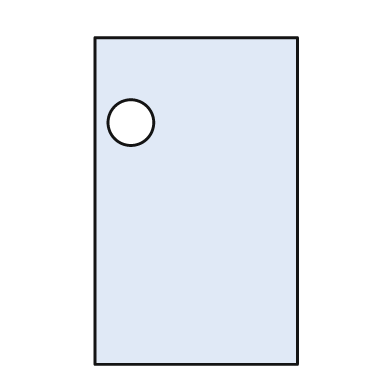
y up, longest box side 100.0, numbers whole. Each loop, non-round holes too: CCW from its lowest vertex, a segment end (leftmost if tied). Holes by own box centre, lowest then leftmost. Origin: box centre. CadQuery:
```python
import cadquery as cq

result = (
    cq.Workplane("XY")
    .moveTo(-31.0, -50.0)
    .lineTo(31.0, -50.0)
    .lineTo(31.0, 50.0)
    .lineTo(-31.0, 50.0)
    .close()
    .moveTo(-20.0, 24.0)
    .circle(7.0)
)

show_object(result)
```